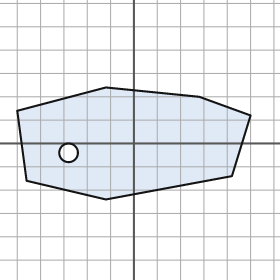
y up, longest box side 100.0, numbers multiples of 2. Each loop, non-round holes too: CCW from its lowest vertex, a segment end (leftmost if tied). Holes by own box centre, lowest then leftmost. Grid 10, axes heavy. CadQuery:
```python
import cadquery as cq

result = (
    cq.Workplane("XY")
    .moveTo(-12.0, -24.0)
    .lineTo(42.0, -14.0)
    .lineTo(50.0, 12.0)
    .lineTo(28.0, 20.0)
    .lineTo(-12.0, 24.0)
    .lineTo(-50.0, 14.0)
    .lineTo(-46.0, -16.0)
    .close()
    .moveTo(-28.0, -4.0)
    .circle(4.0)
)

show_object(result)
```